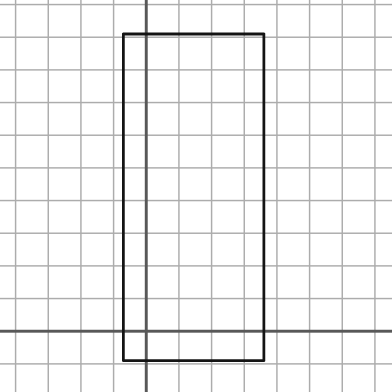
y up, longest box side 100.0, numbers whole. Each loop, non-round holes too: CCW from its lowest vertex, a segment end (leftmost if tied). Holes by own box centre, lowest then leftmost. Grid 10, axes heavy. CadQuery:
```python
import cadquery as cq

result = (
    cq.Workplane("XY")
    .moveTo(-7.0, -9.0)
    .lineTo(36.0, -9.0)
    .lineTo(36.0, 91.0)
    .lineTo(-7.0, 91.0)
    .close()
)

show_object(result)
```